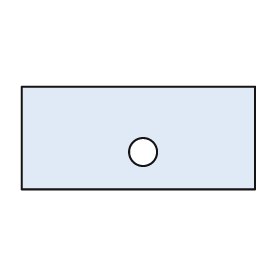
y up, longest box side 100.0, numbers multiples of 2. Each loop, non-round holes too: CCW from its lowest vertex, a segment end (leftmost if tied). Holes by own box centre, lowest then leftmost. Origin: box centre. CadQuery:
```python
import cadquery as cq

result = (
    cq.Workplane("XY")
    .moveTo(-50.0, -22.0)
    .lineTo(50.0, -22.0)
    .lineTo(50.0, 22.0)
    .lineTo(-50.0, 22.0)
    .close()
    .moveTo(2.0, -6.0)
    .circle(6.0)
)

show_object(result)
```